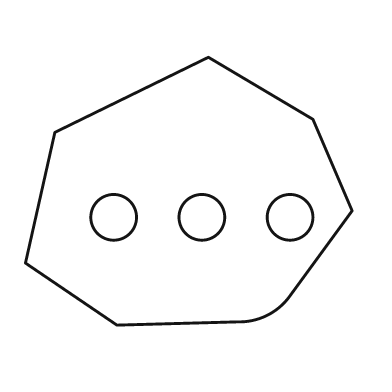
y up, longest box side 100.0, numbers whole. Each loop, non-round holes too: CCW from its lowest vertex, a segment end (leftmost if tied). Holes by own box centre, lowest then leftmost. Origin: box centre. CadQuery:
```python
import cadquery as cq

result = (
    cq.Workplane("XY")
    .moveTo(-22.0, -41.0)
    .lineTo(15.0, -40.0)
    .threePointArc((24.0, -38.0), (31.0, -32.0))
    .lineTo(50.0, -6.0)
    .lineTo(38.0, 22.0)
    .lineTo(6.0, 41.0)
    .lineTo(-41.0, 18.0)
    .lineTo(-50.0, -22.0)
    .close()
    .moveTo(-23.0, -8.0)
    .circle(7.0)
    .moveTo(4.0, -8.0)
    .circle(7.0)
    .moveTo(31.0, -8.0)
    .circle(7.0)
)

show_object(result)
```